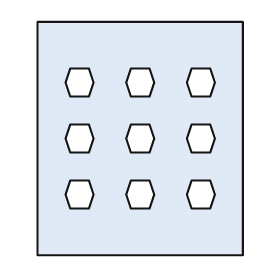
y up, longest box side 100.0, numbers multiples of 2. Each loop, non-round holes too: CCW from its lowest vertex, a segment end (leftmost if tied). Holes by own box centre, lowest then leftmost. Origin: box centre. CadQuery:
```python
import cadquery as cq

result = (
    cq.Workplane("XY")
    .moveTo(-44.0, -50.0)
    .lineTo(44.0, -50.0)
    .lineTo(44.0, 50.0)
    .lineTo(-44.0, 50.0)
    .close()
    .moveTo(-30.0, -30.0)
    .lineTo(-22.0, -30.0)
    .lineTo(-20.0, -24.0)
    .lineTo(-22.0, -18.0)
    .lineTo(-30.0, -18.0)
    .lineTo(-32.0, -24.0)
    .close()
    .moveTo(-4.0, -30.0)
    .lineTo(4.0, -30.0)
    .lineTo(6.0, -24.0)
    .lineTo(4.0, -18.0)
    .lineTo(-4.0, -18.0)
    .lineTo(-6.0, -24.0)
    .close()
    .moveTo(22.0, -30.0)
    .lineTo(30.0, -30.0)
    .lineTo(32.0, -24.0)
    .lineTo(30.0, -18.0)
    .lineTo(22.0, -18.0)
    .lineTo(20.0, -24.0)
    .close()
    .moveTo(-30.0, -6.0)
    .lineTo(-22.0, -6.0)
    .lineTo(-20.0, 0.0)
    .lineTo(-22.0, 6.0)
    .lineTo(-30.0, 6.0)
    .lineTo(-32.0, 0.0)
    .close()
    .moveTo(-4.0, -6.0)
    .lineTo(4.0, -6.0)
    .lineTo(6.0, 0.0)
    .lineTo(4.0, 6.0)
    .lineTo(-4.0, 6.0)
    .lineTo(-6.0, 0.0)
    .close()
    .moveTo(22.0, -6.0)
    .lineTo(30.0, -6.0)
    .lineTo(32.0, 0.0)
    .lineTo(30.0, 6.0)
    .lineTo(22.0, 6.0)
    .lineTo(20.0, 0.0)
    .close()
    .moveTo(-30.0, 18.0)
    .lineTo(-22.0, 18.0)
    .lineTo(-20.0, 24.0)
    .lineTo(-22.0, 30.0)
    .lineTo(-30.0, 30.0)
    .lineTo(-32.0, 24.0)
    .close()
    .moveTo(-4.0, 18.0)
    .lineTo(4.0, 18.0)
    .lineTo(6.0, 24.0)
    .lineTo(4.0, 30.0)
    .lineTo(-4.0, 30.0)
    .lineTo(-6.0, 24.0)
    .close()
    .moveTo(22.0, 18.0)
    .lineTo(30.0, 18.0)
    .lineTo(32.0, 24.0)
    .lineTo(30.0, 30.0)
    .lineTo(22.0, 30.0)
    .lineTo(20.0, 24.0)
    .close()
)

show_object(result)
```